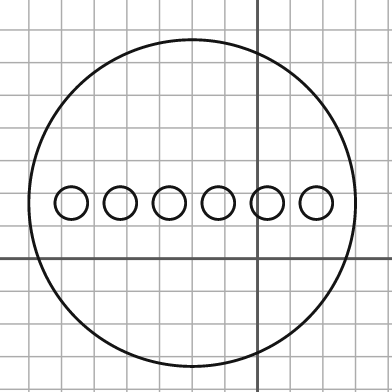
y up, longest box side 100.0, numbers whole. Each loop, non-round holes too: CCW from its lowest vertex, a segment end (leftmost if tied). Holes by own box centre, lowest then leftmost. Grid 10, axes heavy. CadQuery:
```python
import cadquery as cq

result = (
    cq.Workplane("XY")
    .moveTo(-20.0, 17.0)
    .circle(50.0)
    .moveTo(-57.0, 17.0)
    .circle(5.0)
    .moveTo(-42.0, 17.0)
    .circle(5.0)
    .moveTo(-27.0, 17.0)
    .circle(5.0)
    .moveTo(-12.0, 17.0)
    .circle(5.0)
    .moveTo(3.0, 17.0)
    .circle(5.0)
    .moveTo(18.0, 17.0)
    .circle(5.0)
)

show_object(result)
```